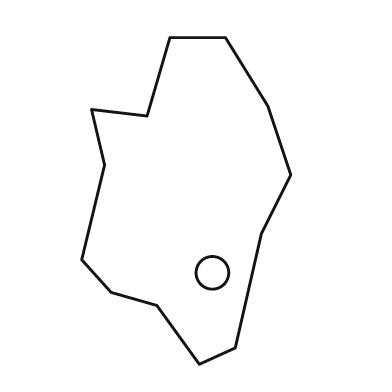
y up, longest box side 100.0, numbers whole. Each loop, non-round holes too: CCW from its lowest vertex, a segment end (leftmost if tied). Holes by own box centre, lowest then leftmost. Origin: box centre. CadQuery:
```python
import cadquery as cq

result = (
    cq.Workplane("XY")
    .moveTo(4.0, -50.0)
    .lineTo(15.0, -45.0)
    .lineTo(23.0, -10.0)
    .lineTo(32.0, 8.0)
    .lineTo(25.0, 29.0)
    .lineTo(12.0, 50.0)
    .lineTo(-5.0, 50.0)
    .lineTo(-12.0, 26.0)
    .lineTo(-29.0, 28.0)
    .lineTo(-25.0, 11.0)
    .lineTo(-32.0, -18.0)
    .lineTo(-23.0, -28.0)
    .lineTo(-9.0, -32.0)
    .close()
    .moveTo(8.0, -22.0)
    .circle(5.0)
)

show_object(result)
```